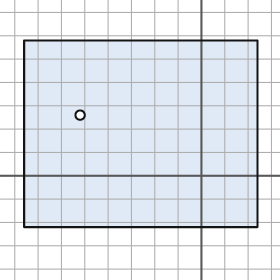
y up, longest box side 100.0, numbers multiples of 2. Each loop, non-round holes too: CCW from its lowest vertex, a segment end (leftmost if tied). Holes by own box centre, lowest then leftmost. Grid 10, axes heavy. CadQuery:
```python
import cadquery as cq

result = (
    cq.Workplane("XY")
    .moveTo(-76.0, -22.0)
    .lineTo(24.0, -22.0)
    .lineTo(24.0, 58.0)
    .lineTo(-76.0, 58.0)
    .close()
    .moveTo(-52.0, 26.0)
    .circle(2.0)
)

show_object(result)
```